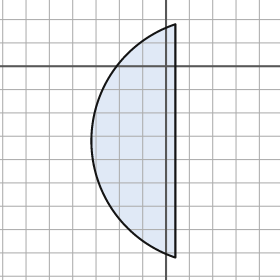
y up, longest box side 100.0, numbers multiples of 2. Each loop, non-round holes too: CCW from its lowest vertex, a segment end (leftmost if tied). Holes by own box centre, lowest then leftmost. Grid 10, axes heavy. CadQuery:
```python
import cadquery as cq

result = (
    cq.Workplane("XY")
    .moveTo(4.0, -82.0)
    .lineTo(4.0, 18.0)
    .threePointArc((-32.0, -32.0), (4.0, -82.0))
    .close()
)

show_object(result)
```